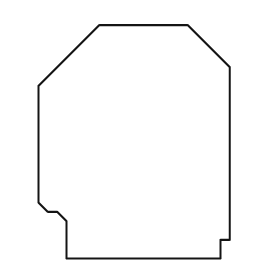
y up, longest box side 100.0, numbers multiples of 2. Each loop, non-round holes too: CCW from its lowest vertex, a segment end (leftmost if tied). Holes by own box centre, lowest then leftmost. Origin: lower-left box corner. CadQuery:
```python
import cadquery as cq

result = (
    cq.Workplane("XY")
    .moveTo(12.0, 0.0)
    .lineTo(78.0, 0.0)
    .lineTo(78.0, 8.0)
    .lineTo(82.0, 8.0)
    .lineTo(82.0, 82.0)
    .lineTo(64.0, 100.0)
    .lineTo(26.0, 100.0)
    .lineTo(0.0, 74.0)
    .lineTo(0.0, 24.0)
    .lineTo(4.0, 20.0)
    .lineTo(8.0, 20.0)
    .lineTo(12.0, 16.0)
    .close()
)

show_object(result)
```